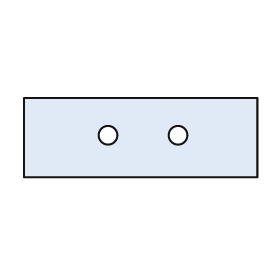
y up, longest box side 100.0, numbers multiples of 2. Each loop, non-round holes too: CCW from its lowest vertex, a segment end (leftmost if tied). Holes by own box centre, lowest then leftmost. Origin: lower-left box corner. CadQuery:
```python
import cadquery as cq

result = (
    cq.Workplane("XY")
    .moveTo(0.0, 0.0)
    .lineTo(100.0, 0.0)
    .lineTo(100.0, 34.0)
    .lineTo(0.0, 34.0)
    .close()
    .moveTo(36.0, 18.0)
    .circle(4.0)
    .moveTo(66.0, 18.0)
    .circle(4.0)
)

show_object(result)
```